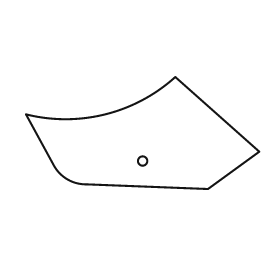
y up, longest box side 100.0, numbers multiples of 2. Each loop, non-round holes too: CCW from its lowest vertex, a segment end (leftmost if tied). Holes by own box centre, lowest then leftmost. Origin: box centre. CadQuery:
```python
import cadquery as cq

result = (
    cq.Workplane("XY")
    .moveTo(28.0, -24.0)
    .lineTo(50.0, -8.0)
    .lineTo(14.0, 24.0)
    .threePointArc((-16.0, 8.0), (-50.0, 8.0))
    .lineTo(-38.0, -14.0)
    .threePointArc((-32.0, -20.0), (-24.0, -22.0))
    .close()
    .moveTo(0.0, -12.0)
    .circle(2.0)
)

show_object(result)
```